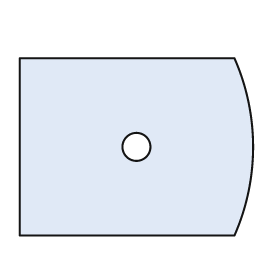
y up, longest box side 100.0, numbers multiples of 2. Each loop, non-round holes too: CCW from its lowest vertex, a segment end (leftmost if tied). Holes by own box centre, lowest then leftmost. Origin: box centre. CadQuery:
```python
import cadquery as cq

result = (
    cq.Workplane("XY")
    .moveTo(-50.0, -38.0)
    .lineTo(42.0, -38.0)
    .threePointArc((50.0, 0.0), (42.0, 38.0))
    .lineTo(-50.0, 38.0)
    .close()
    .moveTo(0.0, 0.0)
    .circle(6.0)
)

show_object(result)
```